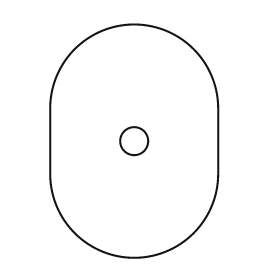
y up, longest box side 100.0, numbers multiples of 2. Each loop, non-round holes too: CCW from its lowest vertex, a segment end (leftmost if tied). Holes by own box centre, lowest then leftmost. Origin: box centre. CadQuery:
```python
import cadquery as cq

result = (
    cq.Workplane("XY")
    .moveTo(-36.0, -14.0)
    .threePointArc((0.0, -50.0), (36.0, -14.0))
    .lineTo(36.0, 14.0)
    .threePointArc((0.0, 50.0), (-36.0, 14.0))
    .close()
    .moveTo(0.0, 0.0)
    .circle(6.0)
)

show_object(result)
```